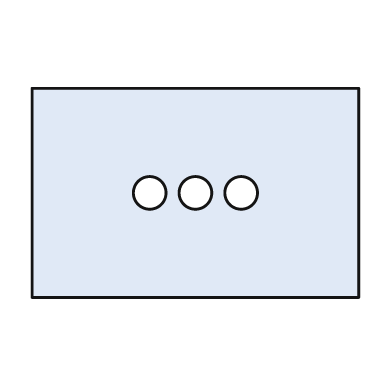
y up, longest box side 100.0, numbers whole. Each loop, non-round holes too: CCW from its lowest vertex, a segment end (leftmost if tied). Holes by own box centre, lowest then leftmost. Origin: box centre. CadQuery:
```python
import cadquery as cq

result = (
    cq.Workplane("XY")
    .moveTo(-50.0, -32.0)
    .lineTo(50.0, -32.0)
    .lineTo(50.0, 32.0)
    .lineTo(-50.0, 32.0)
    .close()
    .moveTo(-14.0, 0.0)
    .circle(5.0)
    .moveTo(0.0, 0.0)
    .circle(5.0)
    .moveTo(14.0, 0.0)
    .circle(5.0)
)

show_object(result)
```